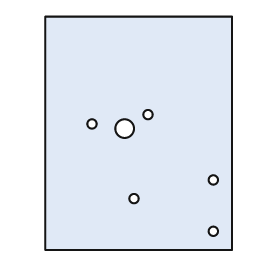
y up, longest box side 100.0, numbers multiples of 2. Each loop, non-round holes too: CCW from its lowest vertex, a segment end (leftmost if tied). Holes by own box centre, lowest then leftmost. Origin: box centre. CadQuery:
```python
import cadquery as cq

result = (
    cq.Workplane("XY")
    .moveTo(-40.0, -50.0)
    .lineTo(40.0, -50.0)
    .lineTo(40.0, 50.0)
    .lineTo(-40.0, 50.0)
    .close()
    .moveTo(32.0, -42.0)
    .circle(2.0)
    .moveTo(-2.0, -28.0)
    .circle(2.0)
    .moveTo(32.0, -20.0)
    .circle(2.0)
    .moveTo(-6.0, 2.0)
    .circle(4.0)
    .moveTo(-20.0, 4.0)
    .circle(2.0)
    .moveTo(4.0, 8.0)
    .circle(2.0)
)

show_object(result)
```